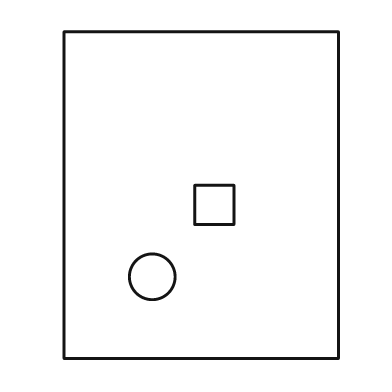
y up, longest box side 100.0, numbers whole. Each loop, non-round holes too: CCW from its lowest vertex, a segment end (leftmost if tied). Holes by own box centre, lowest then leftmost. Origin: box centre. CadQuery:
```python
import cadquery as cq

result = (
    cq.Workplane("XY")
    .moveTo(-42.0, -50.0)
    .lineTo(42.0, -50.0)
    .lineTo(42.0, 50.0)
    .lineTo(-42.0, 50.0)
    .close()
    .moveTo(-15.0, -25.0)
    .circle(7.0)
    .moveTo(-2.0, -9.0)
    .lineTo(10.0, -9.0)
    .lineTo(10.0, 3.0)
    .lineTo(-2.0, 3.0)
    .close()
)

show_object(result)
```